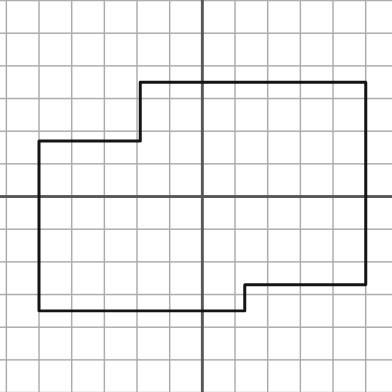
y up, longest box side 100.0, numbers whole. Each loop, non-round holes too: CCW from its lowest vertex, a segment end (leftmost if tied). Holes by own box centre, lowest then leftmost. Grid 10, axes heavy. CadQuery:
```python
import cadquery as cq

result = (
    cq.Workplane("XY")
    .moveTo(-50.0, -35.0)
    .lineTo(13.0, -35.0)
    .lineTo(13.0, -27.0)
    .lineTo(50.0, -27.0)
    .lineTo(50.0, 35.0)
    .lineTo(-19.0, 35.0)
    .lineTo(-19.0, 17.0)
    .lineTo(-50.0, 17.0)
    .close()
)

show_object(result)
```